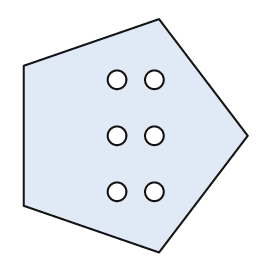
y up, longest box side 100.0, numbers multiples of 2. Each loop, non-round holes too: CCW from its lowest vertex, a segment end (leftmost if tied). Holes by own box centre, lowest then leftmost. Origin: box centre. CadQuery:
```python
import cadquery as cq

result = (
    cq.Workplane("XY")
    .moveTo(10.0, -50.0)
    .lineTo(48.0, 0.0)
    .lineTo(10.0, 50.0)
    .lineTo(-48.0, 30.0)
    .lineTo(-48.0, -30.0)
    .close()
    .moveTo(-8.0, -24.0)
    .circle(4.0)
    .moveTo(8.0, -24.0)
    .circle(4.0)
    .moveTo(-8.0, 0.0)
    .circle(4.0)
    .moveTo(8.0, 0.0)
    .circle(4.0)
    .moveTo(-8.0, 24.0)
    .circle(4.0)
    .moveTo(8.0, 24.0)
    .circle(4.0)
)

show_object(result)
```